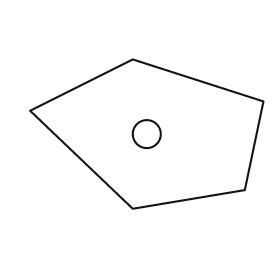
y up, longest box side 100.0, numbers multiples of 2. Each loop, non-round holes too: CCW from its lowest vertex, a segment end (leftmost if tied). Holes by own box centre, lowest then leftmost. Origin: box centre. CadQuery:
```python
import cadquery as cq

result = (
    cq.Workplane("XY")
    .moveTo(-6.0, -32.0)
    .lineTo(42.0, -24.0)
    .lineTo(50.0, 14.0)
    .lineTo(-6.0, 32.0)
    .lineTo(-50.0, 10.0)
    .close()
    .moveTo(0.0, 0.0)
    .circle(6.0)
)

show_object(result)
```